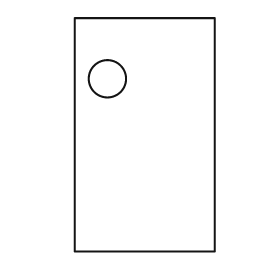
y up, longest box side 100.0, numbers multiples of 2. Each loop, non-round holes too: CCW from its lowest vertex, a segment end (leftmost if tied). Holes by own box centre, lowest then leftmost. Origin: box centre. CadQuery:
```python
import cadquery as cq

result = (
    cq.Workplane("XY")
    .moveTo(-30.0, -50.0)
    .lineTo(30.0, -50.0)
    .lineTo(30.0, 50.0)
    .lineTo(-30.0, 50.0)
    .close()
    .moveTo(-16.0, 24.0)
    .circle(8.0)
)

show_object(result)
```